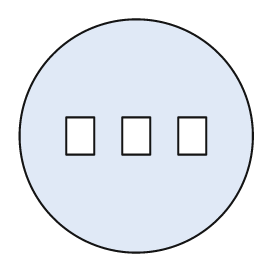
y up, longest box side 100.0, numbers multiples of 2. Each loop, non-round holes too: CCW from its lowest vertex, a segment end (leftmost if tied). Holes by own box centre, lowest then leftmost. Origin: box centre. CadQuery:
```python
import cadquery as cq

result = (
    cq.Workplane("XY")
    .moveTo(0.0, 0.0)
    .circle(50.0)
    .moveTo(-30.0, -8.0)
    .lineTo(-18.0, -8.0)
    .lineTo(-18.0, 8.0)
    .lineTo(-30.0, 8.0)
    .close()
    .moveTo(-6.0, -8.0)
    .lineTo(6.0, -8.0)
    .lineTo(6.0, 8.0)
    .lineTo(-6.0, 8.0)
    .close()
    .moveTo(18.0, -8.0)
    .lineTo(30.0, -8.0)
    .lineTo(30.0, 8.0)
    .lineTo(18.0, 8.0)
    .close()
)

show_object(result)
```